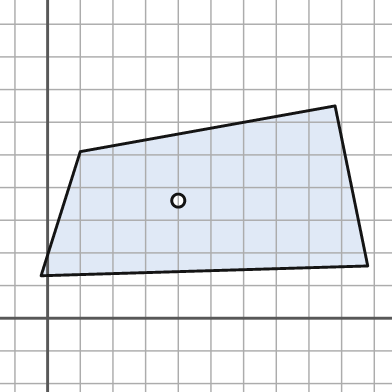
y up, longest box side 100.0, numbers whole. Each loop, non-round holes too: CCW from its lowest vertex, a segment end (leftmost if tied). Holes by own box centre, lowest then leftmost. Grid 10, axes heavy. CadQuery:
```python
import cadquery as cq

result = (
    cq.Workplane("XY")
    .moveTo(-2.0, 13.0)
    .lineTo(98.0, 16.0)
    .lineTo(88.0, 65.0)
    .lineTo(10.0, 51.0)
    .close()
    .moveTo(40.0, 36.0)
    .circle(2.0)
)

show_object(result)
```